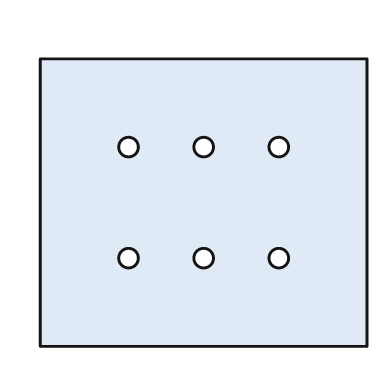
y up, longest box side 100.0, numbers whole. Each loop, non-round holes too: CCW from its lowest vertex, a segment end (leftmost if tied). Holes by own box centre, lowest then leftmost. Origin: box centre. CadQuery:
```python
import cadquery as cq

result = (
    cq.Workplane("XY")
    .moveTo(-50.0, -44.0)
    .lineTo(50.0, -44.0)
    .lineTo(50.0, 44.0)
    .lineTo(-50.0, 44.0)
    .close()
    .moveTo(-23.0, -17.0)
    .circle(3.0)
    .moveTo(0.0, -17.0)
    .circle(3.0)
    .moveTo(23.0, -17.0)
    .circle(3.0)
    .moveTo(-23.0, 17.0)
    .circle(3.0)
    .moveTo(0.0, 17.0)
    .circle(3.0)
    .moveTo(23.0, 17.0)
    .circle(3.0)
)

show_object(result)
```